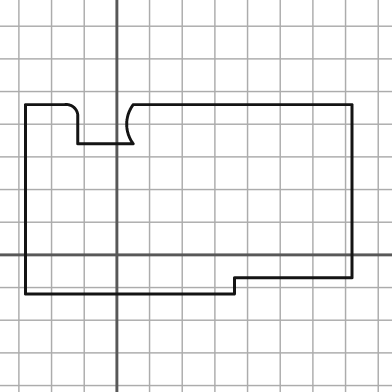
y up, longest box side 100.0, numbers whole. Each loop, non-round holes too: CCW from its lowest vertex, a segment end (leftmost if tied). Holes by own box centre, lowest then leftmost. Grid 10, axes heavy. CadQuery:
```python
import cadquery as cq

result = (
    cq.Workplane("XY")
    .moveTo(-28.0, -12.0)
    .lineTo(36.0, -12.0)
    .lineTo(36.0, -7.0)
    .lineTo(72.0, -7.0)
    .lineTo(72.0, 46.0)
    .lineTo(5.0, 46.0)
    .threePointArc((3.0, 40.0), (5.0, 34.0))
    .lineTo(-12.0, 34.0)
    .lineTo(-12.0, 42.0)
    .threePointArc((-13.0, 45.0), (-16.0, 46.0))
    .lineTo(-28.0, 46.0)
    .close()
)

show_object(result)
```